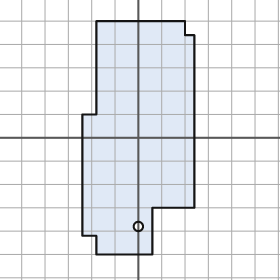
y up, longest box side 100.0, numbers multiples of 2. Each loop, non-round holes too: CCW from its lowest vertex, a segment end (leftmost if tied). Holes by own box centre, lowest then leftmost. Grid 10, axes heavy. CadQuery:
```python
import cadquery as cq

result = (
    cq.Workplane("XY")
    .moveTo(-18.0, -50.0)
    .lineTo(6.0, -50.0)
    .lineTo(6.0, -30.0)
    .lineTo(24.0, -30.0)
    .lineTo(24.0, 44.0)
    .lineTo(20.0, 44.0)
    .lineTo(20.0, 50.0)
    .lineTo(-18.0, 50.0)
    .lineTo(-18.0, 10.0)
    .lineTo(-24.0, 10.0)
    .lineTo(-24.0, -42.0)
    .lineTo(-18.0, -42.0)
    .close()
    .moveTo(0.0, -38.0)
    .circle(2.0)
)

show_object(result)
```